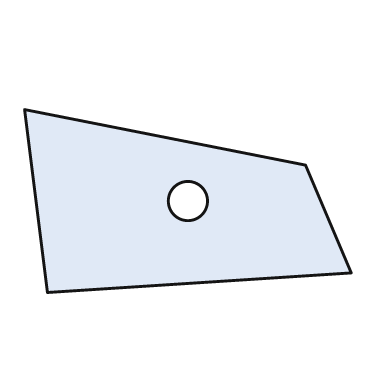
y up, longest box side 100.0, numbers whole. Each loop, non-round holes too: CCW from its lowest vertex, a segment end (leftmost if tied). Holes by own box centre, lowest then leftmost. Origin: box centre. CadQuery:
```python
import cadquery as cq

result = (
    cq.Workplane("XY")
    .moveTo(-43.0, -28.0)
    .lineTo(50.0, -22.0)
    .lineTo(36.0, 11.0)
    .lineTo(-50.0, 28.0)
    .close()
    .moveTo(0.0, 0.0)
    .circle(6.0)
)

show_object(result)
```